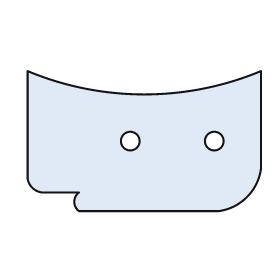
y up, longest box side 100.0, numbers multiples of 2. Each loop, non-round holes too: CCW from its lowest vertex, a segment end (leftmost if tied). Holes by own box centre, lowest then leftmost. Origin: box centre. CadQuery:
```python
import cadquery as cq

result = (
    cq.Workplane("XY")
    .moveTo(-28.0, -30.0)
    .lineTo(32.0, -30.0)
    .threePointArc((44.0, -24.0), (50.0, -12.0))
    .lineTo(50.0, 30.0)
    .threePointArc((0.0, 20.0), (-50.0, 30.0))
    .lineTo(-50.0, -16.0)
    .threePointArc((-48.0, -20.0), (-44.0, -22.0))
    .lineTo(-28.0, -22.0)
    .threePointArc((-30.0, -26.0), (-28.0, -30.0))
    .close()
    .moveTo(-6.0, 0.0)
    .circle(4.0)
    .moveTo(30.0, 0.0)
    .circle(4.0)
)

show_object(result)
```